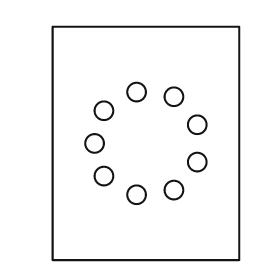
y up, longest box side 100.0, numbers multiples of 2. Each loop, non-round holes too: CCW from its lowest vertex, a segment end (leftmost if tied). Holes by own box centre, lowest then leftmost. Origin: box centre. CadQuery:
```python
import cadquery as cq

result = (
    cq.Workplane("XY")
    .moveTo(-40.0, -50.0)
    .lineTo(40.0, -50.0)
    .lineTo(40.0, 50.0)
    .lineTo(-40.0, 50.0)
    .close()
    .moveTo(-4.0, -22.0)
    .circle(4.0)
    .moveTo(12.0, -20.0)
    .circle(4.0)
    .moveTo(-18.0, -14.0)
    .circle(4.0)
    .moveTo(22.0, -8.0)
    .circle(4.0)
    .moveTo(-22.0, 0.0)
    .circle(4.0)
    .moveTo(22.0, 8.0)
    .circle(4.0)
    .moveTo(-18.0, 14.0)
    .circle(4.0)
    .moveTo(12.0, 20.0)
    .circle(4.0)
    .moveTo(-4.0, 22.0)
    .circle(4.0)
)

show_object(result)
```